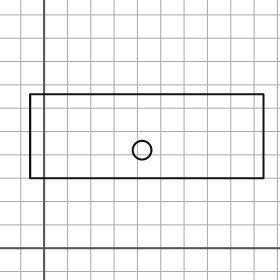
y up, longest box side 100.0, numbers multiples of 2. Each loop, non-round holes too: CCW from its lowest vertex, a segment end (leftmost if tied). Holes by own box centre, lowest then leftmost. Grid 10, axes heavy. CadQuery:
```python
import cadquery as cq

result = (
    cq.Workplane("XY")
    .moveTo(-6.0, 30.0)
    .lineTo(94.0, 30.0)
    .lineTo(94.0, 66.0)
    .lineTo(-6.0, 66.0)
    .close()
    .moveTo(42.0, 42.0)
    .circle(4.0)
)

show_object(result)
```